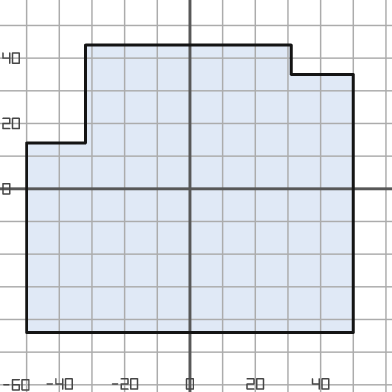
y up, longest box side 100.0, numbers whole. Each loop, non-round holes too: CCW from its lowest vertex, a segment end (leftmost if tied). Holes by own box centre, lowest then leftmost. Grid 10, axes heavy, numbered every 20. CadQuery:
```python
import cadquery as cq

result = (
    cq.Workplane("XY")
    .moveTo(-50.0, -44.0)
    .lineTo(50.0, -44.0)
    .lineTo(50.0, 35.0)
    .lineTo(31.0, 35.0)
    .lineTo(31.0, 44.0)
    .lineTo(-32.0, 44.0)
    .lineTo(-32.0, 14.0)
    .lineTo(-50.0, 14.0)
    .close()
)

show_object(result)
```